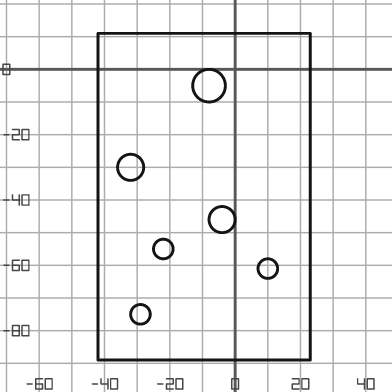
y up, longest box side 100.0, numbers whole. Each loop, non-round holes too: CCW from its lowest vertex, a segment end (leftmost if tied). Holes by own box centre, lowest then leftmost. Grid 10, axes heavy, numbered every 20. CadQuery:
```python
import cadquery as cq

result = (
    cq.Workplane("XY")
    .moveTo(-42.0, -89.0)
    .lineTo(23.0, -89.0)
    .lineTo(23.0, 11.0)
    .lineTo(-42.0, 11.0)
    .close()
    .moveTo(-29.0, -75.0)
    .circle(3.0)
    .moveTo(10.0, -61.0)
    .circle(3.0)
    .moveTo(-22.0, -55.0)
    .circle(3.0)
    .moveTo(-4.0, -46.0)
    .circle(4.0)
    .moveTo(-32.0, -30.0)
    .circle(4.0)
    .moveTo(-8.0, -5.0)
    .circle(5.0)
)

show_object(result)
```